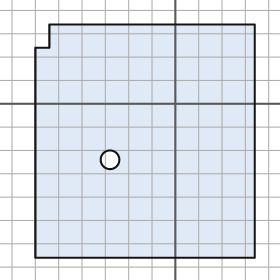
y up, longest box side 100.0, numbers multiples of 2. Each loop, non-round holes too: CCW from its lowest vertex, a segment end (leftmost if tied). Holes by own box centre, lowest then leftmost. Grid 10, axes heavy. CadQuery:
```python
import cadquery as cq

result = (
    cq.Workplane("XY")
    .moveTo(-60.0, -66.0)
    .lineTo(34.0, -66.0)
    .lineTo(34.0, 34.0)
    .lineTo(-54.0, 34.0)
    .lineTo(-54.0, 24.0)
    .lineTo(-60.0, 24.0)
    .close()
    .moveTo(-28.0, -24.0)
    .circle(4.0)
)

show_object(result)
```